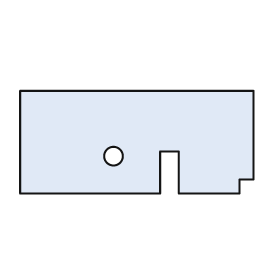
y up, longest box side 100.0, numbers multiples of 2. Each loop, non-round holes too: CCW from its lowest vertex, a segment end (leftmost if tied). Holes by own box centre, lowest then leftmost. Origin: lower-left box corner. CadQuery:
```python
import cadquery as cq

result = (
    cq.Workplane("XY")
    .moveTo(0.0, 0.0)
    .lineTo(60.0, 0.0)
    .lineTo(60.0, 18.0)
    .lineTo(68.0, 18.0)
    .lineTo(68.0, 0.0)
    .lineTo(94.0, 0.0)
    .lineTo(94.0, 6.0)
    .lineTo(100.0, 6.0)
    .lineTo(100.0, 44.0)
    .lineTo(0.0, 44.0)
    .close()
    .moveTo(40.0, 16.0)
    .circle(4.0)
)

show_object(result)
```